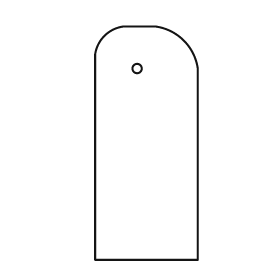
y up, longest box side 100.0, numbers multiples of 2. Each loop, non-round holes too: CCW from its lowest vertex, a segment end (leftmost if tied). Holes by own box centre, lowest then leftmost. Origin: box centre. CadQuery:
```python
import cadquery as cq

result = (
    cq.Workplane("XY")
    .moveTo(-22.0, -50.0)
    .lineTo(22.0, -50.0)
    .lineTo(22.0, 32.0)
    .threePointArc((16.0, 44.0), (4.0, 50.0))
    .lineTo(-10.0, 50.0)
    .threePointArc((-18.0, 46.0), (-22.0, 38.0))
    .close()
    .moveTo(-4.0, 32.0)
    .circle(2.0)
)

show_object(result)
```